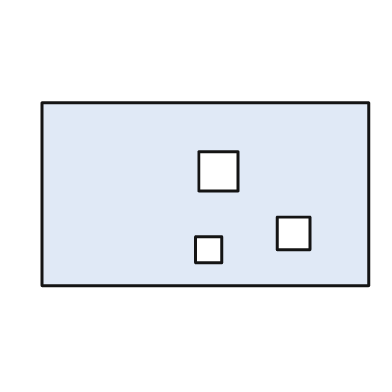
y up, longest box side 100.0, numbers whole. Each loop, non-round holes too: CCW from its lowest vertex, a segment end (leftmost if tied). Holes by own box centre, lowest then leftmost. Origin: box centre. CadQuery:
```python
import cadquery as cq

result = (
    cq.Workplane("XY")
    .moveTo(-50.0, -28.0)
    .lineTo(50.0, -28.0)
    .lineTo(50.0, 28.0)
    .lineTo(-50.0, 28.0)
    .close()
    .moveTo(-3.0, -21.0)
    .lineTo(5.0, -21.0)
    .lineTo(5.0, -13.0)
    .lineTo(-3.0, -13.0)
    .close()
    .moveTo(22.0, -17.0)
    .lineTo(32.0, -17.0)
    .lineTo(32.0, -7.0)
    .lineTo(22.0, -7.0)
    .close()
    .moveTo(-2.0, 1.0)
    .lineTo(10.0, 1.0)
    .lineTo(10.0, 13.0)
    .lineTo(-2.0, 13.0)
    .close()
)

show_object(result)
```